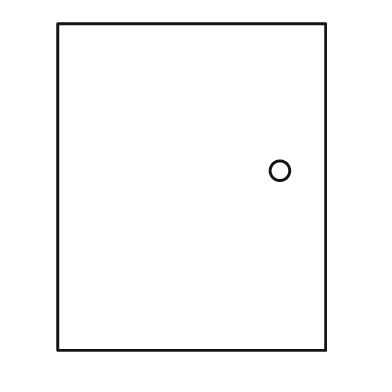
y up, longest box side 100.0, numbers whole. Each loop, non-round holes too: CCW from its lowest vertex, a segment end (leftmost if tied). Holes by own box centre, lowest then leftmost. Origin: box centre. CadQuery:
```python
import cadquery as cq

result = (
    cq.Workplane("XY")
    .moveTo(-41.0, -50.0)
    .lineTo(41.0, -50.0)
    .lineTo(41.0, 50.0)
    .lineTo(-41.0, 50.0)
    .close()
    .moveTo(27.0, 5.0)
    .circle(3.0)
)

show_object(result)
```